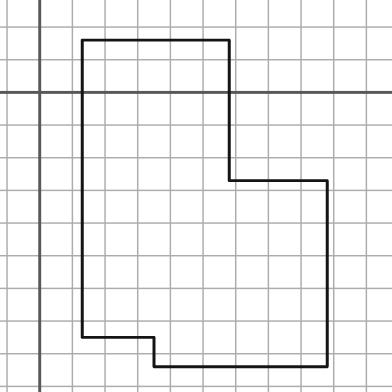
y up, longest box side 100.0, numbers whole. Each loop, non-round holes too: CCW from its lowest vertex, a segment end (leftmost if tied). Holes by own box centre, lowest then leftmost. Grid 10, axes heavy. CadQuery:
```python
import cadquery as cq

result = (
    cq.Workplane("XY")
    .moveTo(35.0, -84.0)
    .lineTo(88.0, -84.0)
    .lineTo(88.0, -27.0)
    .lineTo(58.0, -27.0)
    .lineTo(58.0, 16.0)
    .lineTo(13.0, 16.0)
    .lineTo(13.0, -75.0)
    .lineTo(35.0, -75.0)
    .close()
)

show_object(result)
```